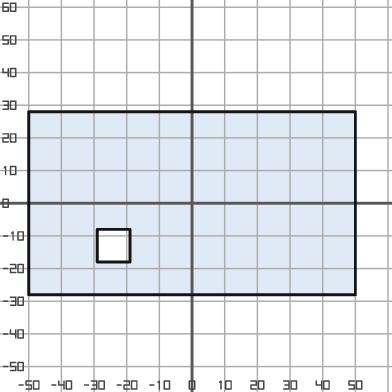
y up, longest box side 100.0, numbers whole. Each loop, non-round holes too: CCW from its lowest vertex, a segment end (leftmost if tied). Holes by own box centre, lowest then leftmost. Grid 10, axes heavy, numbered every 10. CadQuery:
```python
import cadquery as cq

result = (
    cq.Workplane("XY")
    .moveTo(-50.0, -28.0)
    .lineTo(50.0, -28.0)
    .lineTo(50.0, 28.0)
    .lineTo(-50.0, 28.0)
    .close()
    .moveTo(-29.0, -18.0)
    .lineTo(-19.0, -18.0)
    .lineTo(-19.0, -8.0)
    .lineTo(-29.0, -8.0)
    .close()
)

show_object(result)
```